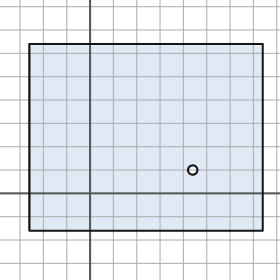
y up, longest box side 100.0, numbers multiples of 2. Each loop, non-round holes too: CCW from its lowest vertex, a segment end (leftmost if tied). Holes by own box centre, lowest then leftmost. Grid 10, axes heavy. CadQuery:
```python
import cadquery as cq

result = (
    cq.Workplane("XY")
    .moveTo(-26.0, -16.0)
    .lineTo(74.0, -16.0)
    .lineTo(74.0, 64.0)
    .lineTo(-26.0, 64.0)
    .close()
    .moveTo(44.0, 10.0)
    .circle(2.0)
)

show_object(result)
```